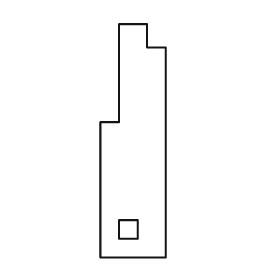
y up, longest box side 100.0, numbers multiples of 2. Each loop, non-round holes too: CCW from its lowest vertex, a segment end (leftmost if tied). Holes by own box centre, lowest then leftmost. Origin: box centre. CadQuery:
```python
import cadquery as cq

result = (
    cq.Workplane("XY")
    .moveTo(-14.0, -50.0)
    .lineTo(14.0, -50.0)
    .lineTo(14.0, 40.0)
    .lineTo(6.0, 40.0)
    .lineTo(6.0, 50.0)
    .lineTo(-6.0, 50.0)
    .lineTo(-6.0, 8.0)
    .lineTo(-14.0, 8.0)
    .close()
    .moveTo(-6.0, -42.0)
    .lineTo(2.0, -42.0)
    .lineTo(2.0, -34.0)
    .lineTo(-6.0, -34.0)
    .close()
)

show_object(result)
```